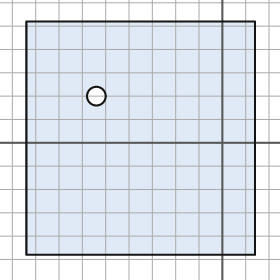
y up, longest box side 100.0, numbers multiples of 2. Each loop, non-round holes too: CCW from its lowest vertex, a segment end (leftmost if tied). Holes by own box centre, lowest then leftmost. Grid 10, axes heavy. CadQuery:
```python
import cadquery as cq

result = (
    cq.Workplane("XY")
    .moveTo(-84.0, -48.0)
    .lineTo(14.0, -48.0)
    .lineTo(14.0, 52.0)
    .lineTo(-84.0, 52.0)
    .close()
    .moveTo(-54.0, 20.0)
    .circle(4.0)
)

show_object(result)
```